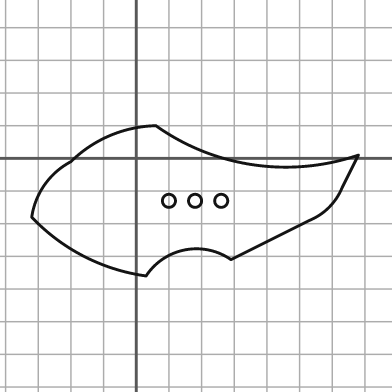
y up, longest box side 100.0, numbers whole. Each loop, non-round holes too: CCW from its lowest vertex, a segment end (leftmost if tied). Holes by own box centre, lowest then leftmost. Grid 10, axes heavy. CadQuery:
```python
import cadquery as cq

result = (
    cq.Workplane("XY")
    .moveTo(3.0, -36.0)
    .threePointArc((15.0, -28.0), (29.0, -31.0))
    .lineTo(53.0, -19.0)
    .threePointArc((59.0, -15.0), (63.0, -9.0))
    .lineTo(68.0, 1.0)
    .threePointArc((36.0, -2.0), (6.0, 10.0))
    .threePointArc((-8.0, 7.0), (-20.0, -1.0))
    .threePointArc((-28.0, -8.0), (-32.0, -18.0))
    .threePointArc((-16.0, -30.0), (3.0, -36.0))
    .close()
    .moveTo(10.0, -13.0)
    .circle(2.0)
    .moveTo(18.0, -13.0)
    .circle(2.0)
    .moveTo(26.0, -13.0)
    .circle(2.0)
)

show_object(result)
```